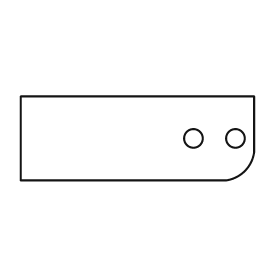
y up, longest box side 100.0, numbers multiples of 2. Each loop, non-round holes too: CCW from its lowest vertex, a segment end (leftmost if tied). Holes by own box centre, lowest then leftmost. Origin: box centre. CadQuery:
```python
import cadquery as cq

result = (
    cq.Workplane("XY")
    .moveTo(-50.0, -18.0)
    .lineTo(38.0, -18.0)
    .threePointArc((46.0, -14.0), (50.0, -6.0))
    .lineTo(50.0, 18.0)
    .lineTo(-50.0, 18.0)
    .close()
    .moveTo(24.0, 0.0)
    .circle(4.0)
    .moveTo(42.0, 0.0)
    .circle(4.0)
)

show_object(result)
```